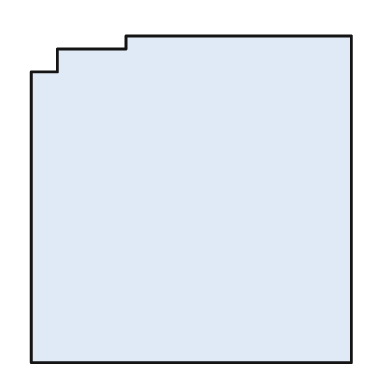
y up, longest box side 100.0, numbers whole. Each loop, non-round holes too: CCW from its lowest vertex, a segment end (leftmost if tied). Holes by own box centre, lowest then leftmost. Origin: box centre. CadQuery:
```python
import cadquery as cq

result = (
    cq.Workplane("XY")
    .moveTo(-49.0, -50.0)
    .lineTo(49.0, -50.0)
    .lineTo(49.0, 50.0)
    .lineTo(-20.0, 50.0)
    .lineTo(-20.0, 46.0)
    .lineTo(-41.0, 46.0)
    .lineTo(-41.0, 39.0)
    .lineTo(-49.0, 39.0)
    .close()
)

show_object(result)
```